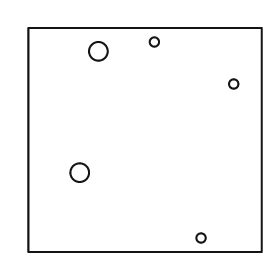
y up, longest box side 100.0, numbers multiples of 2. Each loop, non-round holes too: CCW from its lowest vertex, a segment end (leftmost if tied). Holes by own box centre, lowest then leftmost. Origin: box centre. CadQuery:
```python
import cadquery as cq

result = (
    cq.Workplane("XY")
    .moveTo(-50.0, -48.0)
    .lineTo(50.0, -48.0)
    .lineTo(50.0, 48.0)
    .lineTo(-50.0, 48.0)
    .close()
    .moveTo(24.0, -42.0)
    .circle(2.0)
    .moveTo(-28.0, -14.0)
    .circle(4.0)
    .moveTo(38.0, 24.0)
    .circle(2.0)
    .moveTo(-20.0, 38.0)
    .circle(4.0)
    .moveTo(4.0, 42.0)
    .circle(2.0)
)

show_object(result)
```